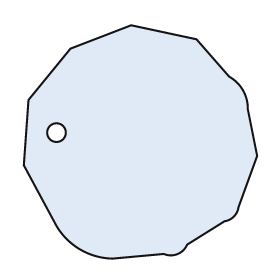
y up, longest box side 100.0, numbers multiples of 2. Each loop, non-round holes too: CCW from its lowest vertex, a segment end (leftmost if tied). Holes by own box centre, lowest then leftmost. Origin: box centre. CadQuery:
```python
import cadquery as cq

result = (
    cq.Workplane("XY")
    .moveTo(-12.0, -50.0)
    .lineTo(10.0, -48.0)
    .threePointArc((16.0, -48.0), (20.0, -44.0))
    .lineTo(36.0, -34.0)
    .threePointArc((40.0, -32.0), (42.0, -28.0))
    .lineTo(50.0, -6.0)
    .lineTo(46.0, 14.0)
    .threePointArc((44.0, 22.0), (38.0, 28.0))
    .lineTo(24.0, 44.0)
    .lineTo(-4.0, 50.0)
    .lineTo(-30.0, 40.0)
    .lineTo(-48.0, 18.0)
    .lineTo(-50.0, -10.0)
    .lineTo(-36.0, -36.0)
    .threePointArc((-26.0, -46.0), (-12.0, -50.0))
    .close()
    .moveTo(-36.0, 4.0)
    .circle(4.0)
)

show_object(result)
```